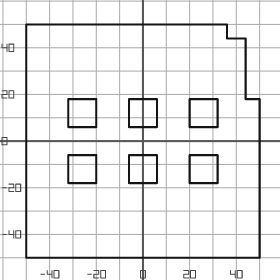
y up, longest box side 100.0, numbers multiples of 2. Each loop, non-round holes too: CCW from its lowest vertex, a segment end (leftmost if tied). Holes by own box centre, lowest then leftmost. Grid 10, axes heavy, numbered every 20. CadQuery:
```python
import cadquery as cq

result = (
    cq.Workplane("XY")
    .moveTo(-50.0, -50.0)
    .lineTo(50.0, -50.0)
    .lineTo(50.0, 18.0)
    .lineTo(44.0, 18.0)
    .lineTo(44.0, 44.0)
    .lineTo(36.0, 44.0)
    .lineTo(36.0, 50.0)
    .lineTo(-50.0, 50.0)
    .close()
    .moveTo(-32.0, -18.0)
    .lineTo(-20.0, -18.0)
    .lineTo(-20.0, -6.0)
    .lineTo(-32.0, -6.0)
    .close()
    .moveTo(-6.0, -18.0)
    .lineTo(6.0, -18.0)
    .lineTo(6.0, -6.0)
    .lineTo(-6.0, -6.0)
    .close()
    .moveTo(20.0, -18.0)
    .lineTo(32.0, -18.0)
    .lineTo(32.0, -6.0)
    .lineTo(20.0, -6.0)
    .close()
    .moveTo(-32.0, 6.0)
    .lineTo(-20.0, 6.0)
    .lineTo(-20.0, 18.0)
    .lineTo(-32.0, 18.0)
    .close()
    .moveTo(-6.0, 6.0)
    .lineTo(6.0, 6.0)
    .lineTo(6.0, 18.0)
    .lineTo(-6.0, 18.0)
    .close()
    .moveTo(20.0, 6.0)
    .lineTo(32.0, 6.0)
    .lineTo(32.0, 18.0)
    .lineTo(20.0, 18.0)
    .close()
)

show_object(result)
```